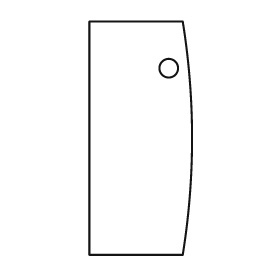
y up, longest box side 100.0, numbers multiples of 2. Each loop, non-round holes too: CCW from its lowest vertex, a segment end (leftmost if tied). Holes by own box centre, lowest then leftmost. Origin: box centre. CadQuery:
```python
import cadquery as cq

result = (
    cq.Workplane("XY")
    .moveTo(-22.0, -50.0)
    .lineTo(18.0, -50.0)
    .threePointArc((22.0, 0.0), (18.0, 50.0))
    .lineTo(-22.0, 50.0)
    .close()
    .moveTo(12.0, 30.0)
    .circle(4.0)
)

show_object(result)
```